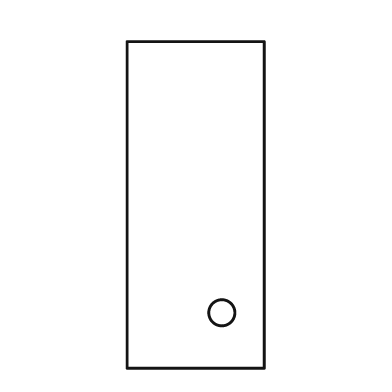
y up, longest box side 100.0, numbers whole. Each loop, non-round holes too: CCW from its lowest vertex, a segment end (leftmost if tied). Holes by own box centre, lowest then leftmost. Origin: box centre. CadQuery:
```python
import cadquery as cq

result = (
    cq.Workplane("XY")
    .moveTo(-21.0, -50.0)
    .lineTo(21.0, -50.0)
    .lineTo(21.0, 50.0)
    .lineTo(-21.0, 50.0)
    .close()
    .moveTo(8.0, -33.0)
    .circle(4.0)
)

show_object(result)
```